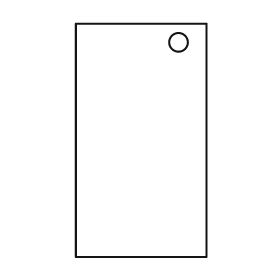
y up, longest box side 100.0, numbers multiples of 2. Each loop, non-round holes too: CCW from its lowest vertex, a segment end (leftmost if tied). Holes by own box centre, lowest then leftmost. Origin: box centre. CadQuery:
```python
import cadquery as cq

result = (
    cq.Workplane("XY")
    .moveTo(-28.0, -50.0)
    .lineTo(28.0, -50.0)
    .lineTo(28.0, 50.0)
    .lineTo(-28.0, 50.0)
    .close()
    .moveTo(16.0, 42.0)
    .circle(4.0)
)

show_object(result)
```